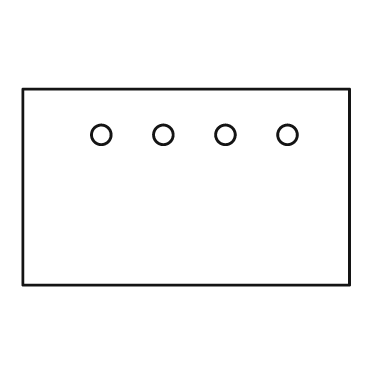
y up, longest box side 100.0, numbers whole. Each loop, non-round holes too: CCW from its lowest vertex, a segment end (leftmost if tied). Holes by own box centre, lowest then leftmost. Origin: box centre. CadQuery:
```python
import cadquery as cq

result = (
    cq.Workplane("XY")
    .moveTo(-50.0, -30.0)
    .lineTo(50.0, -30.0)
    .lineTo(50.0, 30.0)
    .lineTo(-50.0, 30.0)
    .close()
    .moveTo(-26.0, 16.0)
    .circle(3.0)
    .moveTo(-7.0, 16.0)
    .circle(3.0)
    .moveTo(12.0, 16.0)
    .circle(3.0)
    .moveTo(31.0, 16.0)
    .circle(3.0)
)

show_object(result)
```